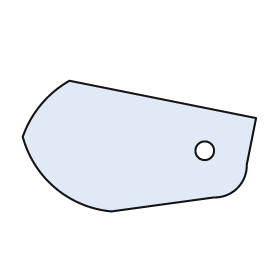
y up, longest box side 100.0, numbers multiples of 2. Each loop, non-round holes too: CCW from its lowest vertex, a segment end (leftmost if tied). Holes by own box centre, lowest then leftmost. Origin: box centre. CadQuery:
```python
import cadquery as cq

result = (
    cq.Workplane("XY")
    .moveTo(-12.0, -28.0)
    .lineTo(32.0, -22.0)
    .threePointArc((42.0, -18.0), (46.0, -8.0))
    .lineTo(50.0, 12.0)
    .lineTo(-30.0, 28.0)
    .threePointArc((-42.0, 18.0), (-50.0, 4.0))
    .threePointArc((-36.0, -18.0), (-12.0, -28.0))
    .close()
    .moveTo(28.0, -2.0)
    .circle(4.0)
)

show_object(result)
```